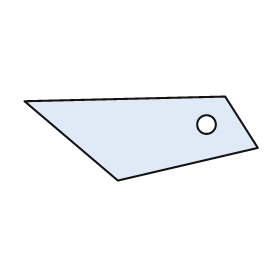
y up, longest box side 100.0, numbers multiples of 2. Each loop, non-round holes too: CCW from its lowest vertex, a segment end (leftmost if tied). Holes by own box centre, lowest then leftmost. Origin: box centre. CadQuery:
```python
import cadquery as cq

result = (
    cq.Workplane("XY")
    .moveTo(-10.0, -18.0)
    .lineTo(50.0, -4.0)
    .lineTo(36.0, 18.0)
    .lineTo(-50.0, 16.0)
    .close()
    .moveTo(28.0, 6.0)
    .circle(4.0)
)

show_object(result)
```